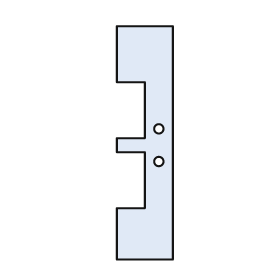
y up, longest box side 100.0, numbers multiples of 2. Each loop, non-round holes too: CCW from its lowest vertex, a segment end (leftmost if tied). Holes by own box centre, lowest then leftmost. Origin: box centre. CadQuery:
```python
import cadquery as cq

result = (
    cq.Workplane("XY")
    .moveTo(-12.0, -50.0)
    .lineTo(12.0, -50.0)
    .lineTo(12.0, 50.0)
    .lineTo(-12.0, 50.0)
    .lineTo(-12.0, 26.0)
    .lineTo(0.0, 26.0)
    .lineTo(0.0, 2.0)
    .lineTo(-12.0, 2.0)
    .lineTo(-12.0, -4.0)
    .lineTo(0.0, -4.0)
    .lineTo(0.0, -28.0)
    .lineTo(-12.0, -28.0)
    .close()
    .moveTo(6.0, -8.0)
    .circle(2.0)
    .moveTo(6.0, 6.0)
    .circle(2.0)
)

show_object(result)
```